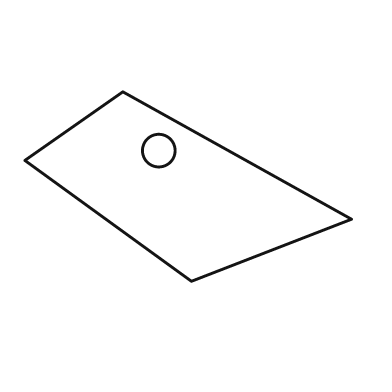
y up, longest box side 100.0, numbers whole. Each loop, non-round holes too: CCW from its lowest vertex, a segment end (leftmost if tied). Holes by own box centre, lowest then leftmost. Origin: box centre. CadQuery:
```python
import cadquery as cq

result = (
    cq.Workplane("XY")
    .moveTo(1.0, -29.0)
    .lineTo(50.0, -10.0)
    .lineTo(-20.0, 29.0)
    .lineTo(-50.0, 8.0)
    .close()
    .moveTo(-9.0, 11.0)
    .circle(5.0)
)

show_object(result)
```